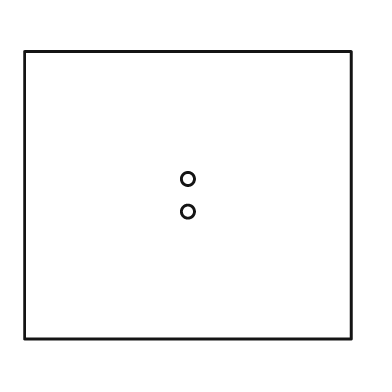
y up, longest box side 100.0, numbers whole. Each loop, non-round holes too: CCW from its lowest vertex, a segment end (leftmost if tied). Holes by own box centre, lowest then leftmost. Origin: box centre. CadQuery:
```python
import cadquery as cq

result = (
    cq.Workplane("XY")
    .moveTo(-50.0, -44.0)
    .lineTo(50.0, -44.0)
    .lineTo(50.0, 44.0)
    .lineTo(-50.0, 44.0)
    .close()
    .moveTo(0.0, -5.0)
    .circle(2.0)
    .moveTo(0.0, 5.0)
    .circle(2.0)
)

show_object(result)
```